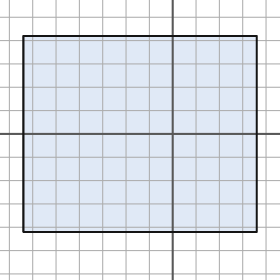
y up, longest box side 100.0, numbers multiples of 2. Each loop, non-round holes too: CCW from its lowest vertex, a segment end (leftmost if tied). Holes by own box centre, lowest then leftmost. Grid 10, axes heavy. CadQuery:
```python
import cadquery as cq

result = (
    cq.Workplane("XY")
    .moveTo(-64.0, -42.0)
    .lineTo(36.0, -42.0)
    .lineTo(36.0, 42.0)
    .lineTo(-64.0, 42.0)
    .close()
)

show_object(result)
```